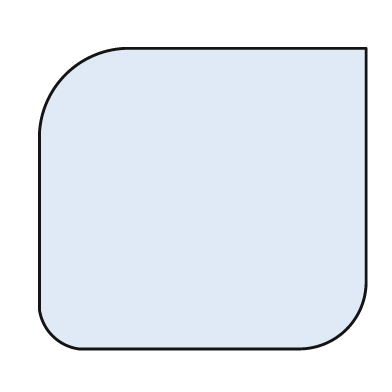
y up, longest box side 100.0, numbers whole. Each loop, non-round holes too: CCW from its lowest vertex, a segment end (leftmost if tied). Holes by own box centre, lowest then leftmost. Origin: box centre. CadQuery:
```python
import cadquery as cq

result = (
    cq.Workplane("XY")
    .moveTo(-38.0, -46.0)
    .lineTo(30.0, -46.0)
    .threePointArc((44.0, -40.0), (50.0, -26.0))
    .lineTo(50.0, 46.0)
    .lineTo(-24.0, 46.0)
    .threePointArc((-42.0, 38.0), (-50.0, 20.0))
    .lineTo(-50.0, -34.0)
    .threePointArc((-46.0, -42.0), (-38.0, -46.0))
    .close()
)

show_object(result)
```